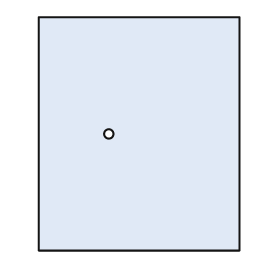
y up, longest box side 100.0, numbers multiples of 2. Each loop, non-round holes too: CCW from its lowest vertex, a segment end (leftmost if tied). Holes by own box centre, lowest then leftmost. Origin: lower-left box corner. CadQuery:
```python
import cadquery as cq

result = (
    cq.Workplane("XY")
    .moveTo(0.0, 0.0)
    .lineTo(86.0, 0.0)
    .lineTo(86.0, 100.0)
    .lineTo(0.0, 100.0)
    .close()
    .moveTo(30.0, 50.0)
    .circle(2.0)
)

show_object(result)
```